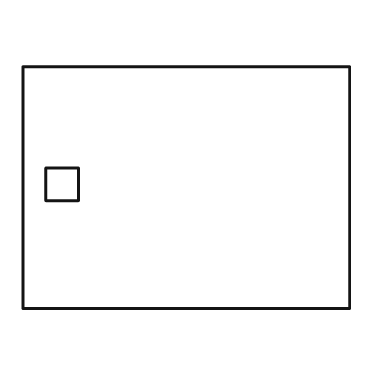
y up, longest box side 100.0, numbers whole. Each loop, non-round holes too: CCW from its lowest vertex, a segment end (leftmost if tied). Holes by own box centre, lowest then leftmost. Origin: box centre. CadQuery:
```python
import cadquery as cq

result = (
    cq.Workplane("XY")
    .moveTo(-50.0, -37.0)
    .lineTo(50.0, -37.0)
    .lineTo(50.0, 37.0)
    .lineTo(-50.0, 37.0)
    .close()
    .moveTo(-43.0, -4.0)
    .lineTo(-33.0, -4.0)
    .lineTo(-33.0, 6.0)
    .lineTo(-43.0, 6.0)
    .close()
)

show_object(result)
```